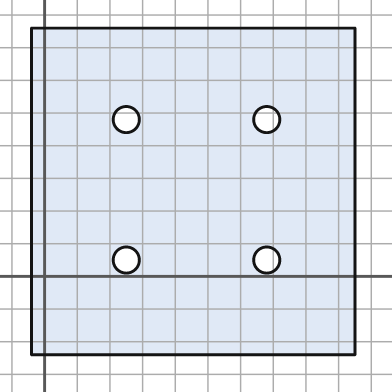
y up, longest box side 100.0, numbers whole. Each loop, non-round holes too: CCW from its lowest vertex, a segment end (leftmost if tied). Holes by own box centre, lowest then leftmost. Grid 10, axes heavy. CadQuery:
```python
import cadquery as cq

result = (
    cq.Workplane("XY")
    .moveTo(-4.0, -24.0)
    .lineTo(95.0, -24.0)
    .lineTo(95.0, 76.0)
    .lineTo(-4.0, 76.0)
    .close()
    .moveTo(25.0, 5.0)
    .circle(4.0)
    .moveTo(68.0, 5.0)
    .circle(4.0)
    .moveTo(25.0, 48.0)
    .circle(4.0)
    .moveTo(68.0, 48.0)
    .circle(4.0)
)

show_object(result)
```